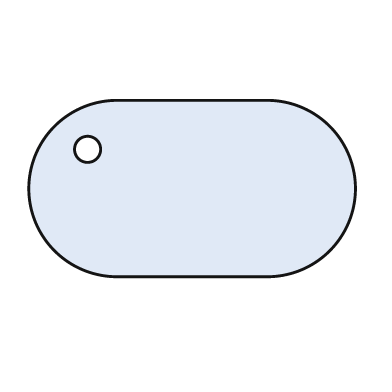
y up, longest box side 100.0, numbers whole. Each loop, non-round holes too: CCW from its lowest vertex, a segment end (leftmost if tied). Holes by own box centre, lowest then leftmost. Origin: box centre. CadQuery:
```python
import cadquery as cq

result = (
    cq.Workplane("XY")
    .moveTo(-23.0, -27.0)
    .lineTo(23.0, -27.0)
    .threePointArc((50.0, 0.0), (23.0, 27.0))
    .lineTo(-23.0, 27.0)
    .threePointArc((-50.0, 0.0), (-23.0, -27.0))
    .close()
    .moveTo(-32.0, 12.0)
    .circle(4.0)
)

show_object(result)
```